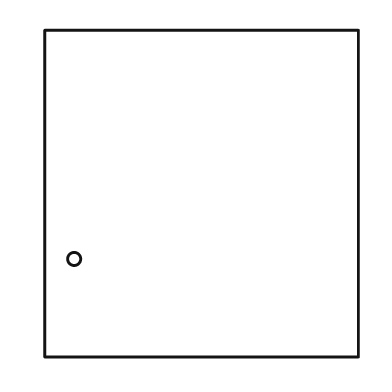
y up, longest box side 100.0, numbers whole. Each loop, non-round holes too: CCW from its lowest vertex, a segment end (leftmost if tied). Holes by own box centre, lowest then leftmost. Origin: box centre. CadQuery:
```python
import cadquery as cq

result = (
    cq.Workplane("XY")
    .moveTo(-48.0, -50.0)
    .lineTo(48.0, -50.0)
    .lineTo(48.0, 50.0)
    .lineTo(-48.0, 50.0)
    .close()
    .moveTo(-39.0, -20.0)
    .circle(2.0)
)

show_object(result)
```